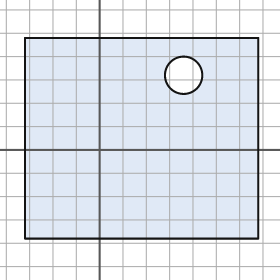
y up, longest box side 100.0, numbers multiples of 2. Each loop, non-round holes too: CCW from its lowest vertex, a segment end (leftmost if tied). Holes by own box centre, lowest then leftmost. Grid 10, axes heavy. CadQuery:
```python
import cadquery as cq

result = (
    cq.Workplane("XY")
    .moveTo(-32.0, -38.0)
    .lineTo(68.0, -38.0)
    .lineTo(68.0, 48.0)
    .lineTo(-32.0, 48.0)
    .close()
    .moveTo(36.0, 32.0)
    .circle(8.0)
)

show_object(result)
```